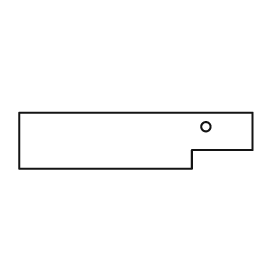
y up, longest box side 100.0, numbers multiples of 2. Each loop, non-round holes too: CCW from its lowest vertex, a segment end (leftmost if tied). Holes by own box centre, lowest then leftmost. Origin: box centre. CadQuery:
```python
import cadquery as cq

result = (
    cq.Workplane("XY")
    .moveTo(-50.0, -12.0)
    .lineTo(24.0, -12.0)
    .lineTo(24.0, -4.0)
    .lineTo(50.0, -4.0)
    .lineTo(50.0, 12.0)
    .lineTo(-50.0, 12.0)
    .close()
    .moveTo(30.0, 6.0)
    .circle(2.0)
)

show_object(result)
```